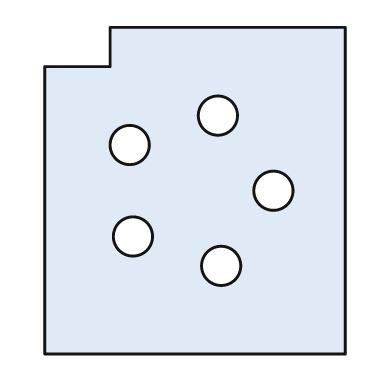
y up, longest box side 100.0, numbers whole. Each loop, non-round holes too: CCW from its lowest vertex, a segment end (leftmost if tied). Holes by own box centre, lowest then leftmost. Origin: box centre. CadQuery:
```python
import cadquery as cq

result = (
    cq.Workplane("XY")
    .moveTo(-46.0, -50.0)
    .lineTo(46.0, -50.0)
    .lineTo(46.0, 50.0)
    .lineTo(-26.0, 50.0)
    .lineTo(-26.0, 38.0)
    .lineTo(-46.0, 38.0)
    .close()
    .moveTo(8.0, -23.0)
    .circle(6.0)
    .moveTo(-19.0, -14.0)
    .circle(6.0)
    .moveTo(24.0, 0.0)
    .circle(6.0)
    .moveTo(-20.0, 14.0)
    .circle(6.0)
    .moveTo(7.0, 23.0)
    .circle(6.0)
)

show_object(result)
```